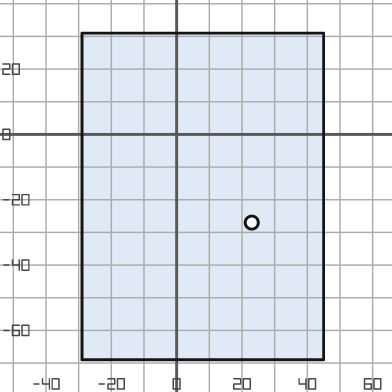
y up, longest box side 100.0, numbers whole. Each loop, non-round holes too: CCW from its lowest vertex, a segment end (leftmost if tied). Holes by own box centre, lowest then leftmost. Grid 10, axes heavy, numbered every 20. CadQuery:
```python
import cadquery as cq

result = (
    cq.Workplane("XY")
    .moveTo(-29.0, -69.0)
    .lineTo(45.0, -69.0)
    .lineTo(45.0, 31.0)
    .lineTo(-29.0, 31.0)
    .close()
    .moveTo(23.0, -27.0)
    .circle(2.0)
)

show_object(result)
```